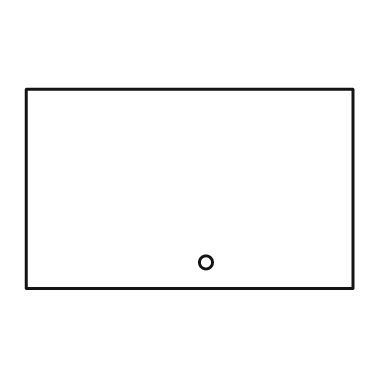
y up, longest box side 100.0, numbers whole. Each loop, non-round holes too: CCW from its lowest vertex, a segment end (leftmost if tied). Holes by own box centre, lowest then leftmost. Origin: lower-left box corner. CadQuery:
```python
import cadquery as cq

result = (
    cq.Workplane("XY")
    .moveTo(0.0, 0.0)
    .lineTo(100.0, 0.0)
    .lineTo(100.0, 61.0)
    .lineTo(0.0, 61.0)
    .close()
    .moveTo(55.0, 8.0)
    .circle(2.0)
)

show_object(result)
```